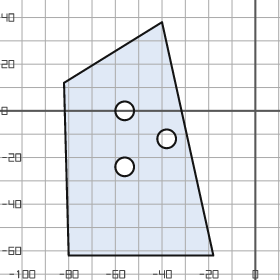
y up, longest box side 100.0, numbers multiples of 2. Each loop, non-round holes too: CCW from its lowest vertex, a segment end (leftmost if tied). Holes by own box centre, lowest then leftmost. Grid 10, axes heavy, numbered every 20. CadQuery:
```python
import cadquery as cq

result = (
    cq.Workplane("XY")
    .moveTo(-80.0, -62.0)
    .lineTo(-18.0, -62.0)
    .lineTo(-40.0, 38.0)
    .lineTo(-82.0, 12.0)
    .close()
    .moveTo(-56.0, -24.0)
    .circle(4.0)
    .moveTo(-38.0, -12.0)
    .circle(4.0)
    .moveTo(-56.0, 0.0)
    .circle(4.0)
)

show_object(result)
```